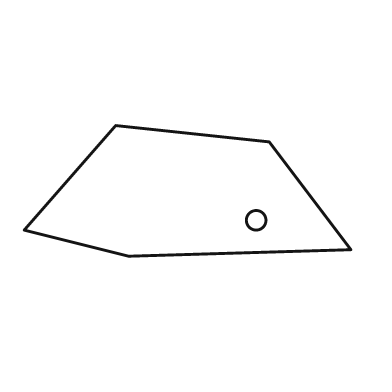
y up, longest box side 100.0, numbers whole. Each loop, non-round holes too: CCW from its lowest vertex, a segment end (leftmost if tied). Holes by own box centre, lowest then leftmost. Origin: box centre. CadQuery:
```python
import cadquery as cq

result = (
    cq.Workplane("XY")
    .moveTo(-18.0, -20.0)
    .lineTo(50.0, -18.0)
    .lineTo(25.0, 15.0)
    .lineTo(-22.0, 20.0)
    .lineTo(-50.0, -12.0)
    .close()
    .moveTo(21.0, -9.0)
    .circle(3.0)
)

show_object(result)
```